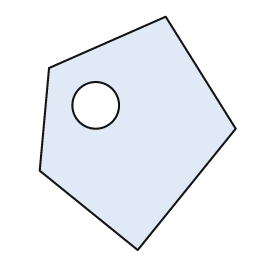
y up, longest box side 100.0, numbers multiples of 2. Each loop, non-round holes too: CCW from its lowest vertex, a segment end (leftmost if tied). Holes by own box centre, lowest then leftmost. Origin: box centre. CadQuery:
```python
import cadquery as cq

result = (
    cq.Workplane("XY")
    .moveTo(0.0, -50.0)
    .lineTo(42.0, 2.0)
    .lineTo(12.0, 50.0)
    .lineTo(-38.0, 28.0)
    .lineTo(-42.0, -16.0)
    .close()
    .moveTo(-18.0, 12.0)
    .circle(10.0)
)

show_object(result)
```